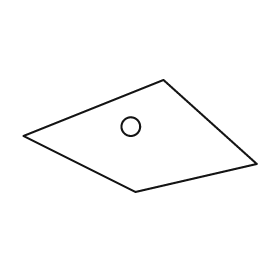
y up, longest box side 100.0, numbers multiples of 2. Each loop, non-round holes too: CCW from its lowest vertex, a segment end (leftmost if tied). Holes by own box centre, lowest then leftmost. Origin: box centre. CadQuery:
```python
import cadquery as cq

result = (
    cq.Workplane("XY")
    .moveTo(-2.0, -24.0)
    .lineTo(50.0, -12.0)
    .lineTo(10.0, 24.0)
    .lineTo(-50.0, 0.0)
    .close()
    .moveTo(-4.0, 4.0)
    .circle(4.0)
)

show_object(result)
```